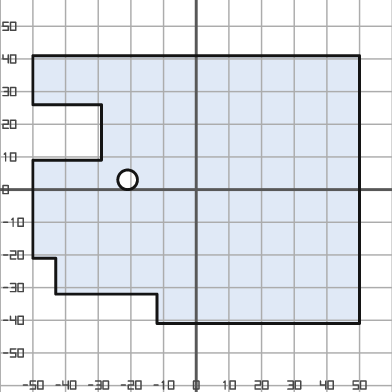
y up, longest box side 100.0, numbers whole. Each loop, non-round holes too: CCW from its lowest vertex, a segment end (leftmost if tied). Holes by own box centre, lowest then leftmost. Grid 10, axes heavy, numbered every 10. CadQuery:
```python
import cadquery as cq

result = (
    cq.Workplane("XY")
    .moveTo(-12.0, -41.0)
    .lineTo(50.0, -41.0)
    .lineTo(50.0, 41.0)
    .lineTo(-50.0, 41.0)
    .lineTo(-50.0, 26.0)
    .lineTo(-29.0, 26.0)
    .lineTo(-29.0, 9.0)
    .lineTo(-50.0, 9.0)
    .lineTo(-50.0, -21.0)
    .lineTo(-43.0, -21.0)
    .lineTo(-43.0, -32.0)
    .lineTo(-12.0, -32.0)
    .close()
    .moveTo(-21.0, 3.0)
    .circle(3.0)
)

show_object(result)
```